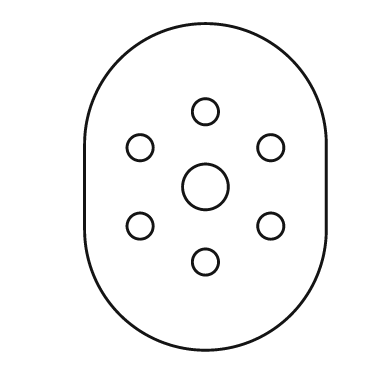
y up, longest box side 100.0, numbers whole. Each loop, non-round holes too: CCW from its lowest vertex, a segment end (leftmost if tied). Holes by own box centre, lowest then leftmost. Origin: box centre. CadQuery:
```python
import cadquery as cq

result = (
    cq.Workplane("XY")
    .moveTo(-37.0, -13.0)
    .threePointArc((0.0, -50.0), (37.0, -13.0))
    .lineTo(37.0, 13.0)
    .threePointArc((0.0, 50.0), (-37.0, 13.0))
    .close()
    .moveTo(0.0, -23.0)
    .circle(4.0)
    .moveTo(-20.0, -12.0)
    .circle(4.0)
    .moveTo(20.0, -12.0)
    .circle(4.0)
    .moveTo(0.0, 0.0)
    .circle(7.0)
    .moveTo(-20.0, 12.0)
    .circle(4.0)
    .moveTo(20.0, 12.0)
    .circle(4.0)
    .moveTo(0.0, 23.0)
    .circle(4.0)
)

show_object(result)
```